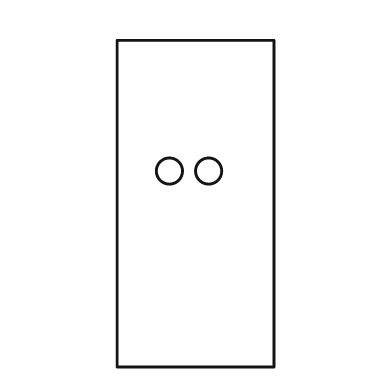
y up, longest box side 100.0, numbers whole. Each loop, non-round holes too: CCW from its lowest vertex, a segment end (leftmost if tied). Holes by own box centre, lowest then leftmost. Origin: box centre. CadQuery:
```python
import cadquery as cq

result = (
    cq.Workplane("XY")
    .moveTo(-24.0, -50.0)
    .lineTo(24.0, -50.0)
    .lineTo(24.0, 50.0)
    .lineTo(-24.0, 50.0)
    .close()
    .moveTo(-8.0, 10.0)
    .circle(4.0)
    .moveTo(4.0, 10.0)
    .circle(4.0)
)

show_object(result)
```